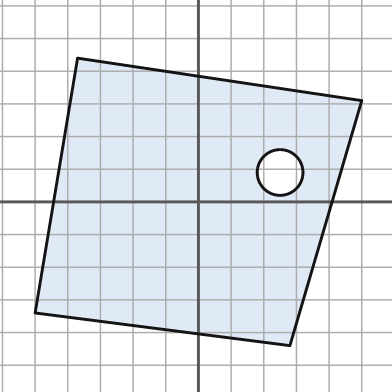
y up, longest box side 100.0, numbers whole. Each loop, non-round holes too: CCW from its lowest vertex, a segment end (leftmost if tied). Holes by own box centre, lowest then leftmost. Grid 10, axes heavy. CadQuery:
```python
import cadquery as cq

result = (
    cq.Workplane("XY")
    .moveTo(28.0, -44.0)
    .lineTo(50.0, 31.0)
    .lineTo(-37.0, 44.0)
    .lineTo(-50.0, -34.0)
    .close()
    .moveTo(25.0, 9.0)
    .circle(7.0)
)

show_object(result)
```